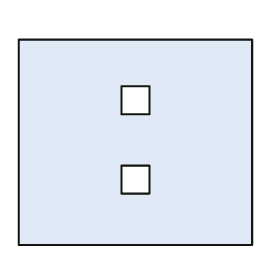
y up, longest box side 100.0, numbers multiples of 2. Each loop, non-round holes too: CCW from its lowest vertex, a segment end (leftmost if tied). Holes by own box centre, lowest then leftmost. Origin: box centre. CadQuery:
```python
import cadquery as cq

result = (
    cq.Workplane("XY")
    .moveTo(-50.0, -44.0)
    .lineTo(50.0, -44.0)
    .lineTo(50.0, 44.0)
    .lineTo(-50.0, 44.0)
    .close()
    .moveTo(-6.0, -22.0)
    .lineTo(6.0, -22.0)
    .lineTo(6.0, -10.0)
    .lineTo(-6.0, -10.0)
    .close()
    .moveTo(-6.0, 12.0)
    .lineTo(6.0, 12.0)
    .lineTo(6.0, 24.0)
    .lineTo(-6.0, 24.0)
    .close()
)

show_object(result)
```